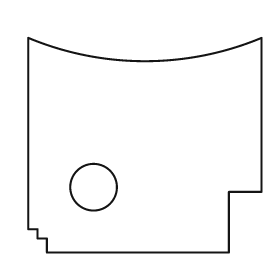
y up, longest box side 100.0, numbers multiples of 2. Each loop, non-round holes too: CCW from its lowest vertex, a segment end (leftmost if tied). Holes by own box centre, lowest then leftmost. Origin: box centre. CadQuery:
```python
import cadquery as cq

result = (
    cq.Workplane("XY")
    .moveTo(-42.0, -46.0)
    .lineTo(36.0, -46.0)
    .lineTo(36.0, -20.0)
    .lineTo(50.0, -20.0)
    .lineTo(50.0, 46.0)
    .threePointArc((0.0, 36.0), (-50.0, 46.0))
    .lineTo(-50.0, -36.0)
    .lineTo(-46.0, -36.0)
    .lineTo(-46.0, -40.0)
    .lineTo(-42.0, -40.0)
    .close()
    .moveTo(-22.0, -18.0)
    .circle(10.0)
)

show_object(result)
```